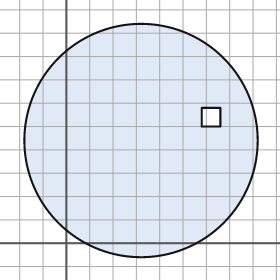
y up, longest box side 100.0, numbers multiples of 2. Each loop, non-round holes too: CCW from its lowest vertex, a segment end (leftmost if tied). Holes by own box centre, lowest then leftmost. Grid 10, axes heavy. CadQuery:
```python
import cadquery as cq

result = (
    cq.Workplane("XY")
    .moveTo(32.0, 44.0)
    .circle(50.0)
    .moveTo(58.0, 50.0)
    .lineTo(66.0, 50.0)
    .lineTo(66.0, 58.0)
    .lineTo(58.0, 58.0)
    .close()
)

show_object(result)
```